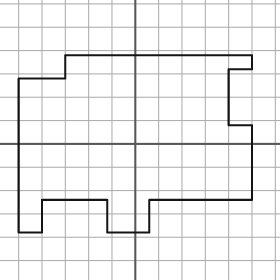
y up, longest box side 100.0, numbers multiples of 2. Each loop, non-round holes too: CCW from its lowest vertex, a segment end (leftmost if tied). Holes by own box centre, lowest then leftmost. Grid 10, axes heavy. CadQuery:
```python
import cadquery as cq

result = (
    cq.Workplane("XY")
    .moveTo(-50.0, -38.0)
    .lineTo(-40.0, -38.0)
    .lineTo(-40.0, -24.0)
    .lineTo(-12.0, -24.0)
    .lineTo(-12.0, -38.0)
    .lineTo(6.0, -38.0)
    .lineTo(6.0, -24.0)
    .lineTo(50.0, -24.0)
    .lineTo(50.0, 8.0)
    .lineTo(40.0, 8.0)
    .lineTo(40.0, 32.0)
    .lineTo(50.0, 32.0)
    .lineTo(50.0, 38.0)
    .lineTo(-30.0, 38.0)
    .lineTo(-30.0, 28.0)
    .lineTo(-50.0, 28.0)
    .close()
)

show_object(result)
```